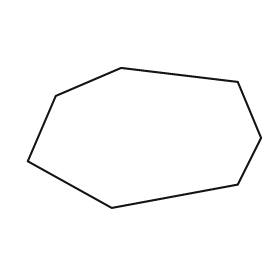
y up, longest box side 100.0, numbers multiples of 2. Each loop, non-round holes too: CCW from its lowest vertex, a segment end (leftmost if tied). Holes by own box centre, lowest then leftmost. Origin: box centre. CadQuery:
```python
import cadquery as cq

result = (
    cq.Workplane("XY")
    .moveTo(-14.0, -30.0)
    .lineTo(40.0, -20.0)
    .lineTo(50.0, 0.0)
    .lineTo(40.0, 24.0)
    .lineTo(-10.0, 30.0)
    .lineTo(-38.0, 18.0)
    .lineTo(-50.0, -10.0)
    .close()
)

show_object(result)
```